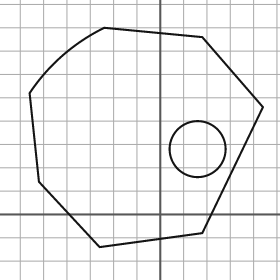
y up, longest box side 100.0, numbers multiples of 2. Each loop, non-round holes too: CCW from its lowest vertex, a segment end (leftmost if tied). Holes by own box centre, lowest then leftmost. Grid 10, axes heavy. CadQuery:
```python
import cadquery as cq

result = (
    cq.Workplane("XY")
    .moveTo(-26.0, -14.0)
    .lineTo(18.0, -8.0)
    .lineTo(44.0, 46.0)
    .lineTo(18.0, 76.0)
    .lineTo(-24.0, 80.0)
    .threePointArc((-42.0, 68.0), (-56.0, 52.0))
    .lineTo(-52.0, 14.0)
    .close()
    .moveTo(16.0, 28.0)
    .circle(12.0)
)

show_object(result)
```